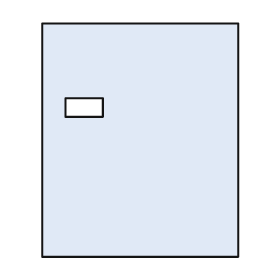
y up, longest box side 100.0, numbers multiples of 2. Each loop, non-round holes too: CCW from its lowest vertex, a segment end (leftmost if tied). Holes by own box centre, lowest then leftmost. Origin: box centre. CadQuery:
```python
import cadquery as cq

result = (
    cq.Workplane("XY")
    .moveTo(-42.0, -50.0)
    .lineTo(42.0, -50.0)
    .lineTo(42.0, 50.0)
    .lineTo(-42.0, 50.0)
    .close()
    .moveTo(-32.0, 10.0)
    .lineTo(-16.0, 10.0)
    .lineTo(-16.0, 18.0)
    .lineTo(-32.0, 18.0)
    .close()
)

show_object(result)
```